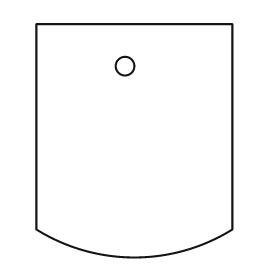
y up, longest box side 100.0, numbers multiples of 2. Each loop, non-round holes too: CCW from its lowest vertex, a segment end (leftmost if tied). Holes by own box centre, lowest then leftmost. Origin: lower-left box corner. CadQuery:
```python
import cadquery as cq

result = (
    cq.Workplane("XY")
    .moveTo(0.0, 12.0)
    .threePointArc((42.0, 0.0), (84.0, 12.0))
    .lineTo(84.0, 100.0)
    .lineTo(0.0, 100.0)
    .close()
    .moveTo(38.0, 82.0)
    .circle(4.0)
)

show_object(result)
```